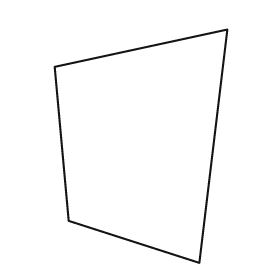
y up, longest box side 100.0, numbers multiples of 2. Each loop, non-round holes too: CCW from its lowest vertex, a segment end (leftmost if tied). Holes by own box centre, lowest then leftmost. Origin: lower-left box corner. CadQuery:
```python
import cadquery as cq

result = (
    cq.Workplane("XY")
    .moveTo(62.0, 0.0)
    .lineTo(74.0, 100.0)
    .lineTo(0.0, 84.0)
    .lineTo(6.0, 18.0)
    .close()
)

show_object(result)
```